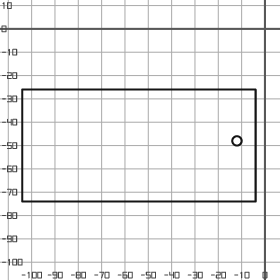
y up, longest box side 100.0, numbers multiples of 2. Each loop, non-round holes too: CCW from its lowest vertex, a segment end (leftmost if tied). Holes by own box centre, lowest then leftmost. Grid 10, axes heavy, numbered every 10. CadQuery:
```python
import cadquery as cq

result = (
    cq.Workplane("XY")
    .moveTo(-104.0, -74.0)
    .lineTo(-4.0, -74.0)
    .lineTo(-4.0, -26.0)
    .lineTo(-104.0, -26.0)
    .close()
    .moveTo(-12.0, -48.0)
    .circle(2.0)
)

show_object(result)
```